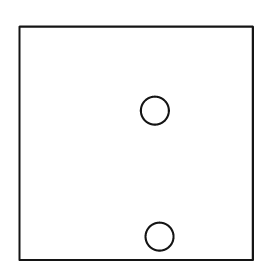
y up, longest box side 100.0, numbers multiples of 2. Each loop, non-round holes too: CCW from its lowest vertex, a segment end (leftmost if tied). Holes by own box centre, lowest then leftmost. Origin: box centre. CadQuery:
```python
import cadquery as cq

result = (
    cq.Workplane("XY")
    .moveTo(-50.0, -50.0)
    .lineTo(50.0, -50.0)
    .lineTo(50.0, 50.0)
    .lineTo(-50.0, 50.0)
    .close()
    .moveTo(10.0, -40.0)
    .circle(6.0)
    .moveTo(8.0, 14.0)
    .circle(6.0)
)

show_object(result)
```